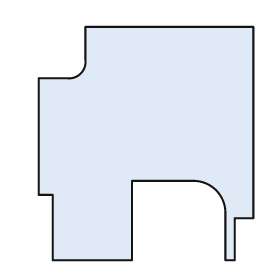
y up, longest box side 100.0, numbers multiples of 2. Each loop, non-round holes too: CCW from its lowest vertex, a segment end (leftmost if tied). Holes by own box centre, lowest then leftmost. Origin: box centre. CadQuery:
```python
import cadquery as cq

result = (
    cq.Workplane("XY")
    .moveTo(-40.0, -50.0)
    .lineTo(-6.0, -50.0)
    .lineTo(-6.0, -16.0)
    .lineTo(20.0, -16.0)
    .threePointArc((30.0, -20.0), (34.0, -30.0))
    .lineTo(34.0, -50.0)
    .lineTo(38.0, -50.0)
    .lineTo(38.0, -32.0)
    .lineTo(46.0, -32.0)
    .lineTo(46.0, 50.0)
    .lineTo(-26.0, 50.0)
    .lineTo(-26.0, 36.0)
    .threePointArc((-28.0, 30.0), (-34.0, 28.0))
    .lineTo(-46.0, 28.0)
    .lineTo(-46.0, -22.0)
    .lineTo(-40.0, -22.0)
    .close()
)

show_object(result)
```